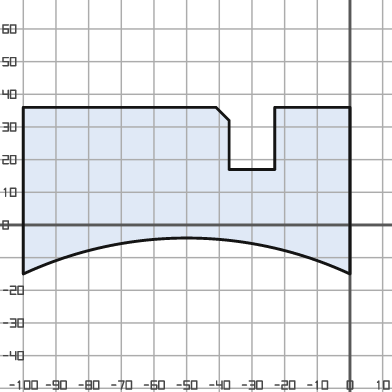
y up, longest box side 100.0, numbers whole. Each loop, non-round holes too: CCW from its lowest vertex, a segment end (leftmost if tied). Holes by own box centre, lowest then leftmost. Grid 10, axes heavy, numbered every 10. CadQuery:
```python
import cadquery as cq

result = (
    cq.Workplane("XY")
    .moveTo(-100.0, -15.0)
    .threePointArc((-50.0, -4.0), (0.0, -15.0))
    .lineTo(0.0, 36.0)
    .lineTo(-23.0, 36.0)
    .lineTo(-23.0, 17.0)
    .lineTo(-37.0, 17.0)
    .lineTo(-37.0, 32.0)
    .lineTo(-41.0, 36.0)
    .lineTo(-100.0, 36.0)
    .close()
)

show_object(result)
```